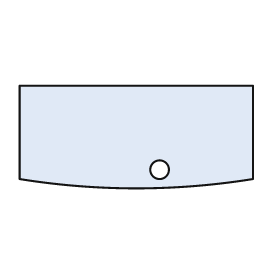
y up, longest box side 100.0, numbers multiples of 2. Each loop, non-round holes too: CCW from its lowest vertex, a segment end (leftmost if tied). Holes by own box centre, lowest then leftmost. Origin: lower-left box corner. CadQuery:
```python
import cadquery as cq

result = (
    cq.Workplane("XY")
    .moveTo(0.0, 4.0)
    .threePointArc((50.0, 0.0), (100.0, 4.0))
    .lineTo(100.0, 44.0)
    .lineTo(0.0, 44.0)
    .close()
    .moveTo(60.0, 8.0)
    .circle(4.0)
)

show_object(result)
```